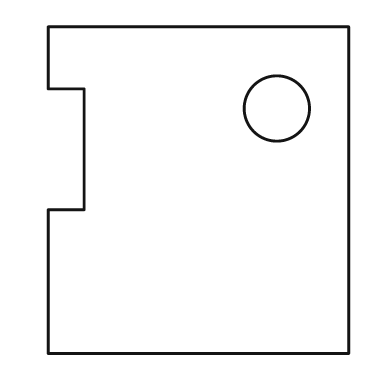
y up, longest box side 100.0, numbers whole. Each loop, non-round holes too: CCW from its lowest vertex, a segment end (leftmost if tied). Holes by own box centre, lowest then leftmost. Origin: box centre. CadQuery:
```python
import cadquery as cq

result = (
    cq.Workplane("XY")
    .moveTo(-46.0, -50.0)
    .lineTo(46.0, -50.0)
    .lineTo(46.0, 50.0)
    .lineTo(-46.0, 50.0)
    .lineTo(-46.0, 31.0)
    .lineTo(-35.0, 31.0)
    .lineTo(-35.0, -6.0)
    .lineTo(-46.0, -6.0)
    .close()
    .moveTo(24.0, 25.0)
    .circle(10.0)
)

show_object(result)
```